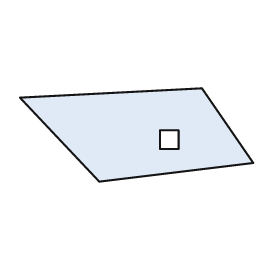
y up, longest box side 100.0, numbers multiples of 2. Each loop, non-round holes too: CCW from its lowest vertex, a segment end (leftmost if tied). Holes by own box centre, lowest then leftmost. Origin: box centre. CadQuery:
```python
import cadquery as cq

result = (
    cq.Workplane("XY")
    .moveTo(-16.0, -20.0)
    .lineTo(50.0, -12.0)
    .lineTo(28.0, 20.0)
    .lineTo(-50.0, 16.0)
    .close()
    .moveTo(10.0, -6.0)
    .lineTo(18.0, -6.0)
    .lineTo(18.0, 2.0)
    .lineTo(10.0, 2.0)
    .close()
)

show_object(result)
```